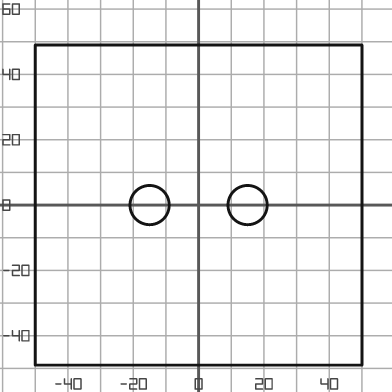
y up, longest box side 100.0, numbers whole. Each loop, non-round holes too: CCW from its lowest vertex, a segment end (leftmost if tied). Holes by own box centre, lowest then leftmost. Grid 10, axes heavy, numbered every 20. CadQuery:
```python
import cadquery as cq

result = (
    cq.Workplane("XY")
    .moveTo(-50.0, -49.0)
    .lineTo(50.0, -49.0)
    .lineTo(50.0, 49.0)
    .lineTo(-50.0, 49.0)
    .close()
    .moveTo(-15.0, 0.0)
    .circle(6.0)
    .moveTo(15.0, 0.0)
    .circle(6.0)
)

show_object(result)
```